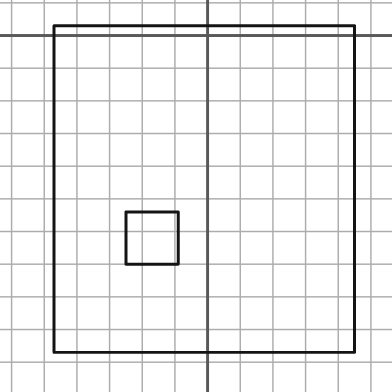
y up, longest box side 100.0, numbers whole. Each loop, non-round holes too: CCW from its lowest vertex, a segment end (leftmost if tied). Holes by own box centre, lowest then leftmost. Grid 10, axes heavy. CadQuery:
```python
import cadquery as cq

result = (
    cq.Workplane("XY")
    .moveTo(-47.0, -97.0)
    .lineTo(45.0, -97.0)
    .lineTo(45.0, 3.0)
    .lineTo(-47.0, 3.0)
    .close()
    .moveTo(-25.0, -70.0)
    .lineTo(-9.0, -70.0)
    .lineTo(-9.0, -54.0)
    .lineTo(-25.0, -54.0)
    .close()
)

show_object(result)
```